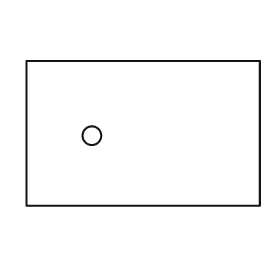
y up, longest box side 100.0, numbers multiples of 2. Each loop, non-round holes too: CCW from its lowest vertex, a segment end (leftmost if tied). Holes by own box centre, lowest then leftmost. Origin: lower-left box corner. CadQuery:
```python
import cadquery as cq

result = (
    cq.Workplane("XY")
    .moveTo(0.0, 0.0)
    .lineTo(100.0, 0.0)
    .lineTo(100.0, 62.0)
    .lineTo(0.0, 62.0)
    .close()
    .moveTo(28.0, 30.0)
    .circle(4.0)
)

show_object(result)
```